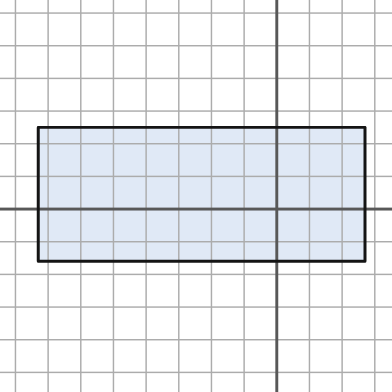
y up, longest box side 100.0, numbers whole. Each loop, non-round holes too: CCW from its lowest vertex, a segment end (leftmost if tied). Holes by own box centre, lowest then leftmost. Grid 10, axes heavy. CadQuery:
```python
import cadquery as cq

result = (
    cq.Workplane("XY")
    .moveTo(-73.0, -16.0)
    .lineTo(27.0, -16.0)
    .lineTo(27.0, 25.0)
    .lineTo(-73.0, 25.0)
    .close()
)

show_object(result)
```